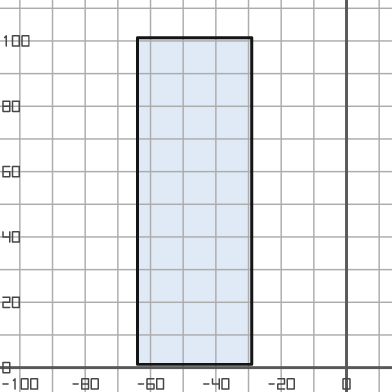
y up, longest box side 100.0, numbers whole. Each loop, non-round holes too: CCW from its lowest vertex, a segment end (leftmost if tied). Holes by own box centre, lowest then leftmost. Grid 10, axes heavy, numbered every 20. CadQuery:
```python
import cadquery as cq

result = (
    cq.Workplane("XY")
    .moveTo(-64.0, 1.0)
    .lineTo(-29.0, 1.0)
    .lineTo(-29.0, 101.0)
    .lineTo(-64.0, 101.0)
    .close()
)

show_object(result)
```